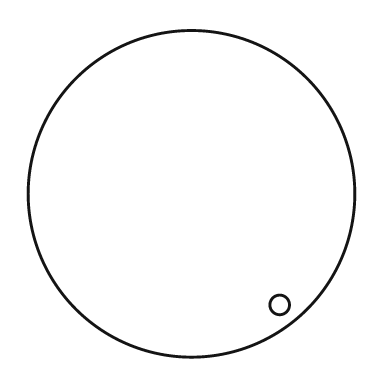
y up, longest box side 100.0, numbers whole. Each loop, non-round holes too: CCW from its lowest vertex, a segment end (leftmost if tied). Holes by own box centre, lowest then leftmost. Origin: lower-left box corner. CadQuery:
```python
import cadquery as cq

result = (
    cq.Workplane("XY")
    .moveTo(50.0, 50.0)
    .circle(50.0)
    .moveTo(77.0, 16.0)
    .circle(3.0)
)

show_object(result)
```